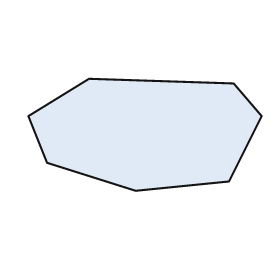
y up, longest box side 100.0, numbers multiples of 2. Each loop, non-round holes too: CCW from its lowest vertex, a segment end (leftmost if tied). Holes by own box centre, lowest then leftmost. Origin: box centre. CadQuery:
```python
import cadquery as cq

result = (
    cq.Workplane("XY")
    .moveTo(-4.0, -24.0)
    .lineTo(36.0, -20.0)
    .lineTo(50.0, 8.0)
    .lineTo(38.0, 22.0)
    .lineTo(-24.0, 24.0)
    .lineTo(-50.0, 8.0)
    .lineTo(-42.0, -12.0)
    .close()
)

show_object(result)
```